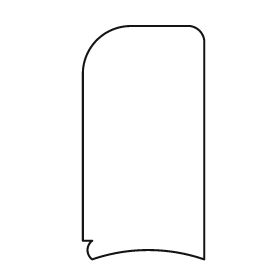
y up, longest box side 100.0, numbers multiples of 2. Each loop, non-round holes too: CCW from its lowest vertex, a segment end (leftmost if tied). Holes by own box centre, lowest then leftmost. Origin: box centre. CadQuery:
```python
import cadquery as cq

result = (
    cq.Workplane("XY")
    .moveTo(-22.0, -50.0)
    .threePointArc((2.0, -46.0), (26.0, -50.0))
    .lineTo(26.0, 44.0)
    .threePointArc((24.0, 48.0), (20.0, 50.0))
    .lineTo(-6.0, 50.0)
    .threePointArc((-20.0, 44.0), (-26.0, 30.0))
    .lineTo(-26.0, -42.0)
    .lineTo(-22.0, -42.0)
    .threePointArc((-24.0, -46.0), (-22.0, -50.0))
    .close()
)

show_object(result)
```